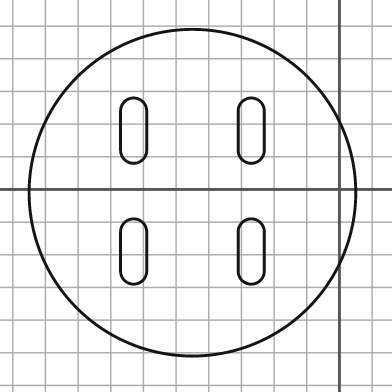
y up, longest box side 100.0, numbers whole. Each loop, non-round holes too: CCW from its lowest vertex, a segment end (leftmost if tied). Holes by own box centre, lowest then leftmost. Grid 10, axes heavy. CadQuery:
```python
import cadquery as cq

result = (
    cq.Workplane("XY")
    .moveTo(-45.0, -1.0)
    .circle(50.0)
    .moveTo(-67.0, -25.0)
    .threePointArc((-63.0, -29.0), (-59.0, -25.0))
    .lineTo(-59.0, -13.0)
    .threePointArc((-63.0, -9.0), (-67.0, -13.0))
    .close()
    .moveTo(-31.0, -25.0)
    .threePointArc((-27.0, -29.0), (-23.0, -25.0))
    .lineTo(-23.0, -13.0)
    .threePointArc((-27.0, -9.0), (-31.0, -13.0))
    .close()
    .moveTo(-67.0, 12.0)
    .threePointArc((-63.0, 8.0), (-59.0, 12.0))
    .lineTo(-59.0, 24.0)
    .threePointArc((-63.0, 28.0), (-67.0, 24.0))
    .close()
    .moveTo(-31.0, 12.0)
    .threePointArc((-27.0, 8.0), (-23.0, 12.0))
    .lineTo(-23.0, 24.0)
    .threePointArc((-27.0, 28.0), (-31.0, 24.0))
    .close()
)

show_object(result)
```